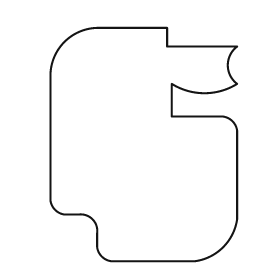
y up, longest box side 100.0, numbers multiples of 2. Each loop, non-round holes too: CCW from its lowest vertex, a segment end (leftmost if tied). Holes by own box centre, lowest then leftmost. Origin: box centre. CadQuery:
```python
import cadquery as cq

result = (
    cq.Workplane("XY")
    .moveTo(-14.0, -50.0)
    .lineTo(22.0, -50.0)
    .threePointArc((34.0, -44.0), (40.0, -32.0))
    .lineTo(40.0, 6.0)
    .threePointArc((38.0, 10.0), (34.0, 12.0))
    .lineTo(12.0, 12.0)
    .lineTo(12.0, 26.0)
    .threePointArc((26.0, 22.0), (40.0, 26.0))
    .threePointArc((36.0, 34.0), (40.0, 42.0))
    .lineTo(10.0, 42.0)
    .lineTo(10.0, 50.0)
    .lineTo(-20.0, 50.0)
    .threePointArc((-34.0, 44.0), (-40.0, 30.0))
    .lineTo(-40.0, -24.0)
    .threePointArc((-38.0, -28.0), (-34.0, -30.0))
    .lineTo(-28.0, -30.0)
    .threePointArc((-22.0, -32.0), (-20.0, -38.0))
    .lineTo(-20.0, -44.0)
    .threePointArc((-18.0, -48.0), (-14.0, -50.0))
    .close()
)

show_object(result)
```